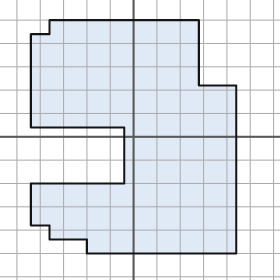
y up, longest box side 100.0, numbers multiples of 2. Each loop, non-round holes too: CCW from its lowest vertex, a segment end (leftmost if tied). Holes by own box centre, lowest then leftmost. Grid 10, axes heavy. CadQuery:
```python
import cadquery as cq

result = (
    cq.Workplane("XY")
    .moveTo(-20.0, -50.0)
    .lineTo(44.0, -50.0)
    .lineTo(44.0, 22.0)
    .lineTo(28.0, 22.0)
    .lineTo(28.0, 50.0)
    .lineTo(-36.0, 50.0)
    .lineTo(-36.0, 44.0)
    .lineTo(-44.0, 44.0)
    .lineTo(-44.0, 4.0)
    .lineTo(-4.0, 4.0)
    .lineTo(-4.0, -20.0)
    .lineTo(-44.0, -20.0)
    .lineTo(-44.0, -38.0)
    .lineTo(-36.0, -38.0)
    .lineTo(-36.0, -44.0)
    .lineTo(-20.0, -44.0)
    .close()
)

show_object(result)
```